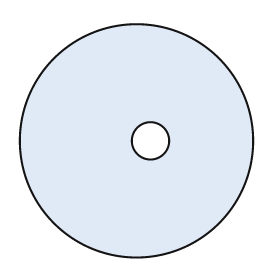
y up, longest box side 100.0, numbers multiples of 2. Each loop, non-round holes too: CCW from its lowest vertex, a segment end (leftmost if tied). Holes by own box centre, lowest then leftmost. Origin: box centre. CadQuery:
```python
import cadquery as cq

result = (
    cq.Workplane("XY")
    .moveTo(0.0, 0.0)
    .circle(50.0)
    .moveTo(6.0, 0.0)
    .circle(8.0)
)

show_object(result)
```